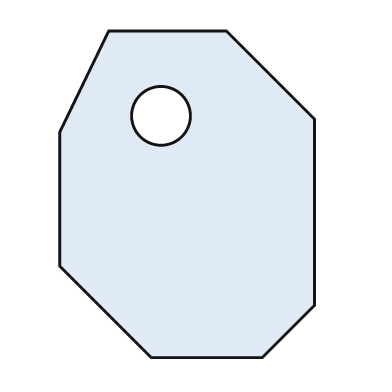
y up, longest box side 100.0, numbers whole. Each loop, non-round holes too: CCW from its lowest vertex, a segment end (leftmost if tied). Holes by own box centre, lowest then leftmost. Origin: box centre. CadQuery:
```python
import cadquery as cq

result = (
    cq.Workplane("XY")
    .moveTo(-11.0, -50.0)
    .lineTo(23.0, -50.0)
    .lineTo(39.0, -34.0)
    .lineTo(39.0, 23.0)
    .lineTo(12.0, 50.0)
    .lineTo(-24.0, 50.0)
    .lineTo(-39.0, 19.0)
    .lineTo(-39.0, -22.0)
    .close()
    .moveTo(-8.0, 24.0)
    .circle(9.0)
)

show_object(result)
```